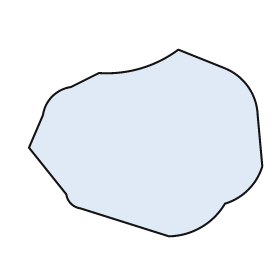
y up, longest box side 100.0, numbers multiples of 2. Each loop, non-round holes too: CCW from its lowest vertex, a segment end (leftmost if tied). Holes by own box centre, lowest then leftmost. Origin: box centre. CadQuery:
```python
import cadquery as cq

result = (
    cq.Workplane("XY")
    .moveTo(10.0, -40.0)
    .threePointArc((24.0, -36.0), (34.0, -26.0))
    .threePointArc((44.0, -20.0), (50.0, -10.0))
    .lineTo(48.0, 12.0)
    .threePointArc((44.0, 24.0), (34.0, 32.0))
    .lineTo(14.0, 40.0)
    .threePointArc((-2.0, 32.0), (-20.0, 30.0))
    .lineTo(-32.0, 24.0)
    .threePointArc((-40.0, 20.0), (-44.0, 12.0))
    .lineTo(-50.0, -2.0)
    .lineTo(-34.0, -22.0)
    .threePointArc((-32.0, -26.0), (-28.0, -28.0))
    .close()
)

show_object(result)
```